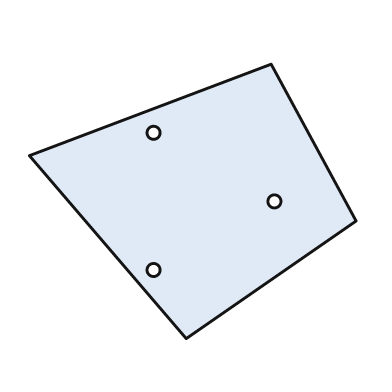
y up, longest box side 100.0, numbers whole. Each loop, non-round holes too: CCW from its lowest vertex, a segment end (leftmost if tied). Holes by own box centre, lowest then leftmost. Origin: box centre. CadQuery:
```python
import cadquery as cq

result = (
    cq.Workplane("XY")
    .moveTo(-2.0, -42.0)
    .lineTo(50.0, -6.0)
    .lineTo(24.0, 42.0)
    .lineTo(-50.0, 14.0)
    .close()
    .moveTo(-12.0, -21.0)
    .circle(2.0)
    .moveTo(25.0, 0.0)
    .circle(2.0)
    .moveTo(-12.0, 21.0)
    .circle(2.0)
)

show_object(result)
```